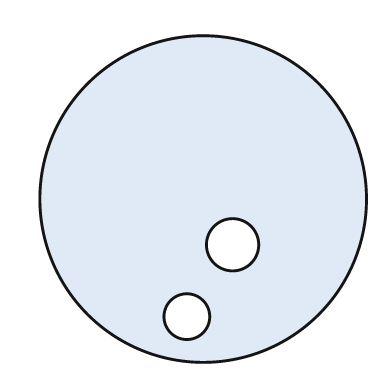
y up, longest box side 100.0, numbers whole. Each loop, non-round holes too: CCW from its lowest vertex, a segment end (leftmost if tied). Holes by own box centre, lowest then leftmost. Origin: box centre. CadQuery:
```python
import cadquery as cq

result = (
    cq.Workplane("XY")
    .moveTo(0.0, 0.0)
    .circle(50.0)
    .moveTo(-5.0, -36.0)
    .circle(7.0)
    .moveTo(9.0, -14.0)
    .circle(8.0)
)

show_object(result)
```